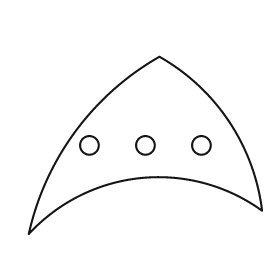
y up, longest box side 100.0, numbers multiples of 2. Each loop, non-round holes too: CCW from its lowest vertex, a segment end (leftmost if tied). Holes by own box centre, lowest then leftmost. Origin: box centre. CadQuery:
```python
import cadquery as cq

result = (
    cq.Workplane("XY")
    .moveTo(-50.0, -38.0)
    .threePointArc((-2.0, -14.0), (50.0, -28.0))
    .threePointArc((36.0, 10.0), (6.0, 38.0))
    .threePointArc((-30.0, 6.0), (-50.0, -38.0))
    .close()
    .moveTo(-24.0, 0.0)
    .circle(4.0)
    .moveTo(0.0, 0.0)
    .circle(4.0)
    .moveTo(24.0, 0.0)
    .circle(4.0)
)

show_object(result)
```